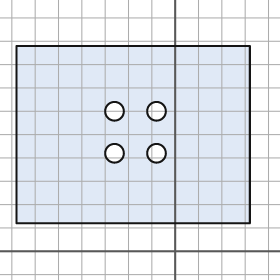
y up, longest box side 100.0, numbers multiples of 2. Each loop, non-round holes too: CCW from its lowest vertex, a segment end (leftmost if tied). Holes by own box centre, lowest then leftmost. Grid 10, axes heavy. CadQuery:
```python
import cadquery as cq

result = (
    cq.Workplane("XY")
    .moveTo(-68.0, 12.0)
    .lineTo(32.0, 12.0)
    .lineTo(32.0, 88.0)
    .lineTo(-68.0, 88.0)
    .close()
    .moveTo(-26.0, 42.0)
    .circle(4.0)
    .moveTo(-8.0, 42.0)
    .circle(4.0)
    .moveTo(-26.0, 60.0)
    .circle(4.0)
    .moveTo(-8.0, 60.0)
    .circle(4.0)
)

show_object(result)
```